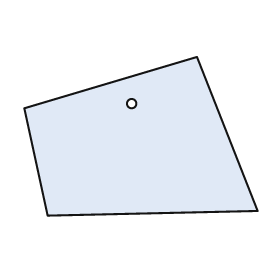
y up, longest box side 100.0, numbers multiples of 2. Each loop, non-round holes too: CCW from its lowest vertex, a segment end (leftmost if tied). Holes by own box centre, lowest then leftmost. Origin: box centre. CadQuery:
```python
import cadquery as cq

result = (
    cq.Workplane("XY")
    .moveTo(-40.0, -34.0)
    .lineTo(50.0, -32.0)
    .lineTo(24.0, 34.0)
    .lineTo(-50.0, 12.0)
    .close()
    .moveTo(-4.0, 14.0)
    .circle(2.0)
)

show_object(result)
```